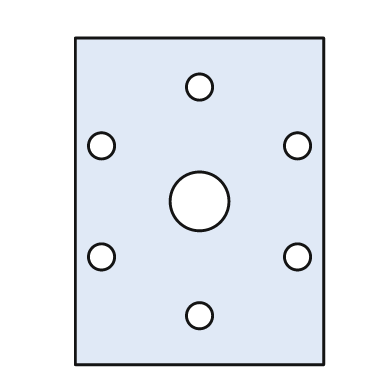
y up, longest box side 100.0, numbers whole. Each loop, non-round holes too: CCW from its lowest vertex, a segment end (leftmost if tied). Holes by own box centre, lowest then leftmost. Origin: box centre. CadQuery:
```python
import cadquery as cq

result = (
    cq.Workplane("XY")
    .moveTo(-38.0, -50.0)
    .lineTo(38.0, -50.0)
    .lineTo(38.0, 50.0)
    .lineTo(-38.0, 50.0)
    .close()
    .moveTo(0.0, -35.0)
    .circle(4.0)
    .moveTo(-30.0, -17.0)
    .circle(4.0)
    .moveTo(30.0, -17.0)
    .circle(4.0)
    .moveTo(0.0, 0.0)
    .circle(9.0)
    .moveTo(-30.0, 17.0)
    .circle(4.0)
    .moveTo(30.0, 17.0)
    .circle(4.0)
    .moveTo(0.0, 35.0)
    .circle(4.0)
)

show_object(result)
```